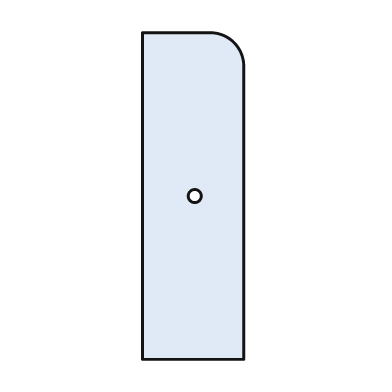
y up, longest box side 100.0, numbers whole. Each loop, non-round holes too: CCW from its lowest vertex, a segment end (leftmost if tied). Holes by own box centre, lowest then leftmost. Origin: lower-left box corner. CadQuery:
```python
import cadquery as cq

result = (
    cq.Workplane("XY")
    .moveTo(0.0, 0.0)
    .lineTo(31.0, 0.0)
    .lineTo(31.0, 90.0)
    .threePointArc((28.0, 97.0), (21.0, 100.0))
    .lineTo(0.0, 100.0)
    .close()
    .moveTo(16.0, 50.0)
    .circle(2.0)
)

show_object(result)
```